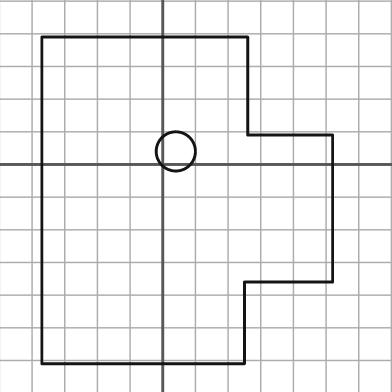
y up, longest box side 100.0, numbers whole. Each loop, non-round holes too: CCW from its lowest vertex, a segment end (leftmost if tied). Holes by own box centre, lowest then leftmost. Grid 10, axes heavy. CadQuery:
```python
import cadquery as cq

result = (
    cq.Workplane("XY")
    .moveTo(-37.0, -61.0)
    .lineTo(25.0, -61.0)
    .lineTo(25.0, -36.0)
    .lineTo(52.0, -36.0)
    .lineTo(52.0, 9.0)
    .lineTo(26.0, 9.0)
    .lineTo(26.0, 39.0)
    .lineTo(-37.0, 39.0)
    .close()
    .moveTo(4.0, 4.0)
    .circle(6.0)
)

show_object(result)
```